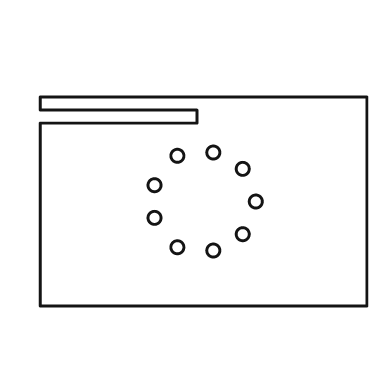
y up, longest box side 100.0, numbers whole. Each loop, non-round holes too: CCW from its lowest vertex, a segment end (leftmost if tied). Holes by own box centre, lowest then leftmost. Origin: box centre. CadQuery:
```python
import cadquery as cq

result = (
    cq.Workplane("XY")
    .moveTo(-50.0, -32.0)
    .lineTo(50.0, -32.0)
    .lineTo(50.0, 32.0)
    .lineTo(-50.0, 32.0)
    .lineTo(-50.0, 28.0)
    .lineTo(-2.0, 28.0)
    .lineTo(-2.0, 24.0)
    .lineTo(-50.0, 24.0)
    .close()
    .moveTo(3.0, -15.0)
    .circle(2.0)
    .moveTo(-8.0, -14.0)
    .circle(2.0)
    .moveTo(12.0, -10.0)
    .circle(2.0)
    .moveTo(-15.0, -5.0)
    .circle(2.0)
    .moveTo(16.0, 0.0)
    .circle(2.0)
    .moveTo(-15.0, 5.0)
    .circle(2.0)
    .moveTo(12.0, 10.0)
    .circle(2.0)
    .moveTo(-8.0, 14.0)
    .circle(2.0)
    .moveTo(3.0, 15.0)
    .circle(2.0)
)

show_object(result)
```